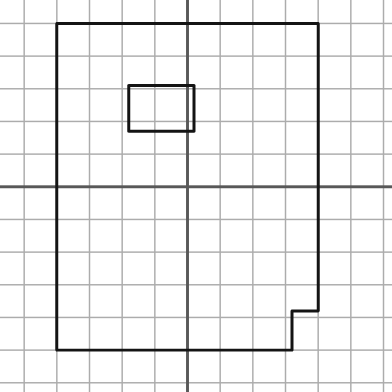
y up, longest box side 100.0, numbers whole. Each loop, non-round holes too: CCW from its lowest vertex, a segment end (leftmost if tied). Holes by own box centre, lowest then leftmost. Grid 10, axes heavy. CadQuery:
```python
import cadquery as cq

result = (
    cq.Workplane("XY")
    .moveTo(-40.0, -50.0)
    .lineTo(32.0, -50.0)
    .lineTo(32.0, -38.0)
    .lineTo(40.0, -38.0)
    .lineTo(40.0, 50.0)
    .lineTo(-40.0, 50.0)
    .close()
    .moveTo(-18.0, 17.0)
    .lineTo(2.0, 17.0)
    .lineTo(2.0, 31.0)
    .lineTo(-18.0, 31.0)
    .close()
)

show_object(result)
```